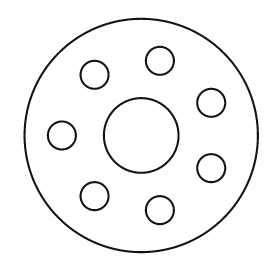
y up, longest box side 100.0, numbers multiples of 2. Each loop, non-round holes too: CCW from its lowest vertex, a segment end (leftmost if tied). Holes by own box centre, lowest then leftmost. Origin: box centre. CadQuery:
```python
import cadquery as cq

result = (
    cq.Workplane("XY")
    .moveTo(0.0, 0.0)
    .circle(50.0)
    .moveTo(8.0, -32.0)
    .circle(6.0)
    .moveTo(-20.0, -26.0)
    .circle(6.0)
    .moveTo(30.0, -14.0)
    .circle(6.0)
    .moveTo(-34.0, 0.0)
    .circle(6.0)
    .moveTo(0.0, 0.0)
    .circle(16.0)
    .moveTo(30.0, 14.0)
    .circle(6.0)
    .moveTo(-20.0, 26.0)
    .circle(6.0)
    .moveTo(8.0, 32.0)
    .circle(6.0)
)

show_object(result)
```